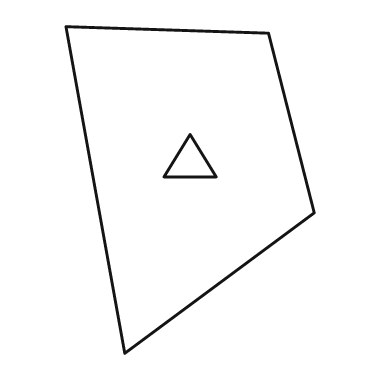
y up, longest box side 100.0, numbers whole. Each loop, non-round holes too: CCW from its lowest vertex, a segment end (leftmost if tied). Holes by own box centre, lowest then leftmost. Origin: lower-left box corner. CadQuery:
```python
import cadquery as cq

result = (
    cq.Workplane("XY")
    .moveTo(18.0, 0.0)
    .lineTo(76.0, 43.0)
    .lineTo(62.0, 98.0)
    .lineTo(0.0, 100.0)
    .close()
    .moveTo(30.0, 54.0)
    .lineTo(46.0, 54.0)
    .lineTo(38.0, 67.0)
    .close()
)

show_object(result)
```